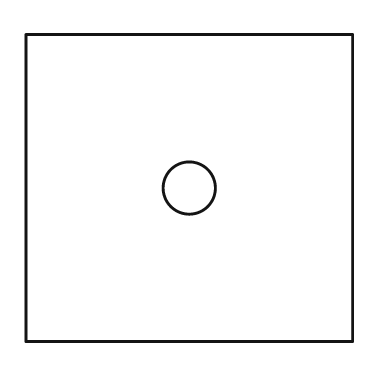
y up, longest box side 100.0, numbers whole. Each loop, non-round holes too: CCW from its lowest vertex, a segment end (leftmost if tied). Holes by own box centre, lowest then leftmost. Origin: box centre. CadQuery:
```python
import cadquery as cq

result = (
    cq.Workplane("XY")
    .moveTo(-50.0, -47.0)
    .lineTo(50.0, -47.0)
    .lineTo(50.0, 47.0)
    .lineTo(-50.0, 47.0)
    .close()
    .moveTo(0.0, 0.0)
    .circle(8.0)
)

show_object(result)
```